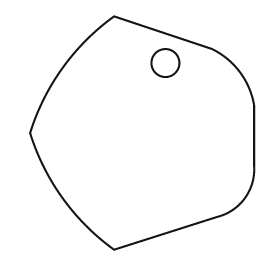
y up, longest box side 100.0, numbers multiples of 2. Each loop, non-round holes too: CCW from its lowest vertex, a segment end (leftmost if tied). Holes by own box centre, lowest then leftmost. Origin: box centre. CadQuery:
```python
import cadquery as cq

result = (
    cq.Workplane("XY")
    .moveTo(-12.0, -50.0)
    .lineTo(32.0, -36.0)
    .threePointArc((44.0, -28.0), (48.0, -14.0))
    .lineTo(48.0, 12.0)
    .threePointArc((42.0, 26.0), (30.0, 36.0))
    .lineTo(-12.0, 50.0)
    .threePointArc((-34.0, 28.0), (-48.0, 0.0))
    .threePointArc((-34.0, -28.0), (-12.0, -50.0))
    .close()
    .moveTo(10.0, 30.0)
    .circle(6.0)
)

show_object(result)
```